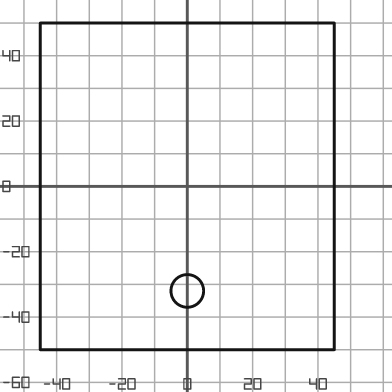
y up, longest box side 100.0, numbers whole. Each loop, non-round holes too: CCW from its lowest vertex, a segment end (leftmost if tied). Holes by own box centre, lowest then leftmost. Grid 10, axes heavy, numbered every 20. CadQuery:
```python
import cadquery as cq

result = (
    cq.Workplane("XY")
    .moveTo(-45.0, -50.0)
    .lineTo(45.0, -50.0)
    .lineTo(45.0, 50.0)
    .lineTo(-45.0, 50.0)
    .close()
    .moveTo(0.0, -32.0)
    .circle(5.0)
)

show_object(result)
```